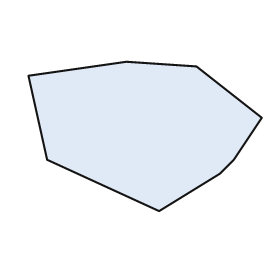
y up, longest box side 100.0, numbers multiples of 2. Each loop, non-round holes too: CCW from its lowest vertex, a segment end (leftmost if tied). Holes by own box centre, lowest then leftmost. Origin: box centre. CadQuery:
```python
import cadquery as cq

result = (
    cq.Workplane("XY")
    .moveTo(6.0, -32.0)
    .lineTo(32.0, -16.0)
    .lineTo(38.0, -10.0)
    .lineTo(50.0, 8.0)
    .lineTo(22.0, 30.0)
    .lineTo(-8.0, 32.0)
    .lineTo(-50.0, 26.0)
    .lineTo(-42.0, -10.0)
    .close()
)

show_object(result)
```